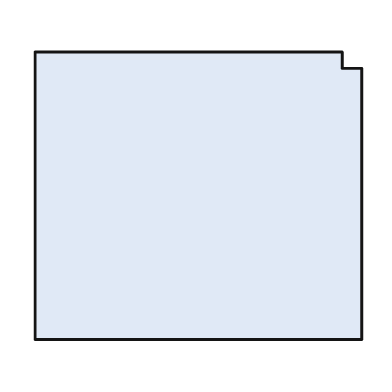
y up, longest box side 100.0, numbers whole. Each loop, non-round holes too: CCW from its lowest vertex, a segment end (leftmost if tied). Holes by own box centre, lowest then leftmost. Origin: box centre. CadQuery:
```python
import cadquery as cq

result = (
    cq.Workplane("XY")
    .moveTo(-50.0, -44.0)
    .lineTo(50.0, -44.0)
    .lineTo(50.0, 39.0)
    .lineTo(44.0, 39.0)
    .lineTo(44.0, 44.0)
    .lineTo(-50.0, 44.0)
    .close()
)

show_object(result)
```